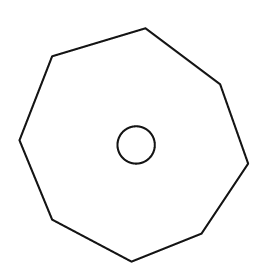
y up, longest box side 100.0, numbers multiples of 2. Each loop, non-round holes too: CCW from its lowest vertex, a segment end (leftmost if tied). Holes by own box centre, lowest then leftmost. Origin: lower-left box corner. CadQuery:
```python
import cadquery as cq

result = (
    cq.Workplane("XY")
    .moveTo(48.0, 0.0)
    .lineTo(78.0, 12.0)
    .lineTo(98.0, 42.0)
    .lineTo(86.0, 76.0)
    .lineTo(54.0, 100.0)
    .lineTo(14.0, 88.0)
    .lineTo(0.0, 52.0)
    .lineTo(14.0, 18.0)
    .close()
    .moveTo(50.0, 50.0)
    .circle(8.0)
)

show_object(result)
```